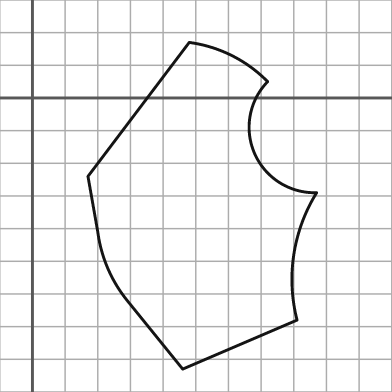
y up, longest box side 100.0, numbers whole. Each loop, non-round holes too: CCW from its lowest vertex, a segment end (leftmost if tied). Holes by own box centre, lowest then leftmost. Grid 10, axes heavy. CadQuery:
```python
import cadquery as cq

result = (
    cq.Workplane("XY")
    .moveTo(46.0, -83.0)
    .lineTo(81.0, -68.0)
    .threePointArc((80.0, -48.0), (87.0, -29.0))
    .threePointArc((68.0, -17.0), (72.0, 5.0))
    .threePointArc((61.0, 13.0), (48.0, 17.0))
    .lineTo(17.0, -24.0)
    .lineTo(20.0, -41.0)
    .threePointArc((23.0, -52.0), (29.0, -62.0))
    .close()
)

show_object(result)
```